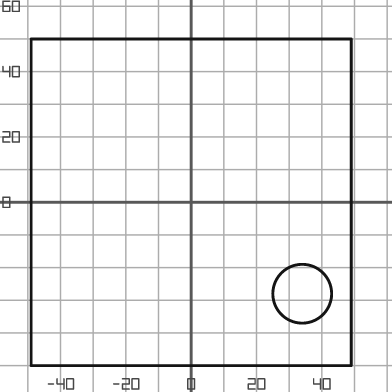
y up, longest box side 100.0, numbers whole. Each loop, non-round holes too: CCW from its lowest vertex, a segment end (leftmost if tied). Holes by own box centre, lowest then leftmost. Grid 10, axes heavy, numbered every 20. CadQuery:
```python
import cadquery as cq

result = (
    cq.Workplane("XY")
    .moveTo(-49.0, -50.0)
    .lineTo(49.0, -50.0)
    .lineTo(49.0, 50.0)
    .lineTo(-49.0, 50.0)
    .close()
    .moveTo(34.0, -28.0)
    .circle(9.0)
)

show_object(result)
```